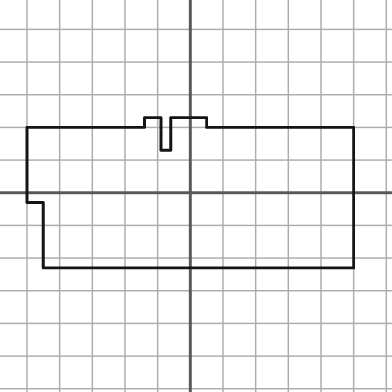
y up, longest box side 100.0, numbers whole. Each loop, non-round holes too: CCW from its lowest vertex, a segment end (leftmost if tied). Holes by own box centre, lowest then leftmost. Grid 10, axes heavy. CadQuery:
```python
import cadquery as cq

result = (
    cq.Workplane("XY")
    .moveTo(-45.0, -23.0)
    .lineTo(50.0, -23.0)
    .lineTo(50.0, 20.0)
    .lineTo(5.0, 20.0)
    .lineTo(5.0, 23.0)
    .lineTo(-6.0, 23.0)
    .lineTo(-6.0, 13.0)
    .lineTo(-9.0, 13.0)
    .lineTo(-9.0, 23.0)
    .lineTo(-14.0, 23.0)
    .lineTo(-14.0, 20.0)
    .lineTo(-50.0, 20.0)
    .lineTo(-50.0, -3.0)
    .lineTo(-45.0, -3.0)
    .close()
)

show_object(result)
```